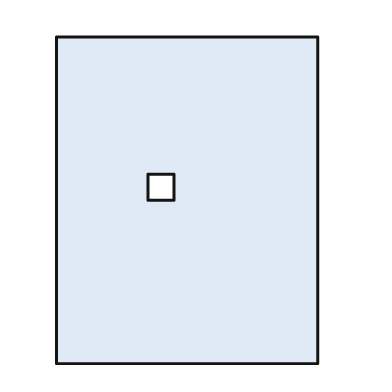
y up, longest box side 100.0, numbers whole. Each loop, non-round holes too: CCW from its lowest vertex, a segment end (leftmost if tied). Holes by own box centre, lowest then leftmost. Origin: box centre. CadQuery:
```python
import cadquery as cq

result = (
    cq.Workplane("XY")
    .moveTo(-40.0, -50.0)
    .lineTo(40.0, -50.0)
    .lineTo(40.0, 50.0)
    .lineTo(-40.0, 50.0)
    .close()
    .moveTo(-12.0, 0.0)
    .lineTo(-4.0, 0.0)
    .lineTo(-4.0, 8.0)
    .lineTo(-12.0, 8.0)
    .close()
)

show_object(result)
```